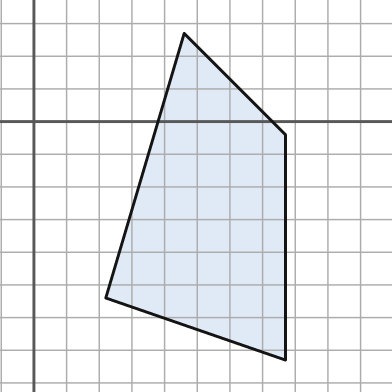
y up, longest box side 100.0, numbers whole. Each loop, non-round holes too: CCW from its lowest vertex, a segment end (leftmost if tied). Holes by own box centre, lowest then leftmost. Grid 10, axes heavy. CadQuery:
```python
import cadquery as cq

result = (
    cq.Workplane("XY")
    .moveTo(77.0, -73.0)
    .lineTo(77.0, -4.0)
    .lineTo(46.0, 27.0)
    .lineTo(22.0, -54.0)
    .close()
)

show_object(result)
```